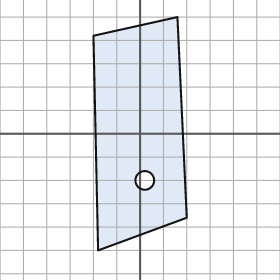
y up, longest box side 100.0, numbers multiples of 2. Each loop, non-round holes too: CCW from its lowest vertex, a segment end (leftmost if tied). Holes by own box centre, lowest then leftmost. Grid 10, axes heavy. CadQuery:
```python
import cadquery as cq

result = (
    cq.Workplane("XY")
    .moveTo(-18.0, -50.0)
    .lineTo(20.0, -36.0)
    .lineTo(16.0, 50.0)
    .lineTo(-20.0, 42.0)
    .close()
    .moveTo(2.0, -20.0)
    .circle(4.0)
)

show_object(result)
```